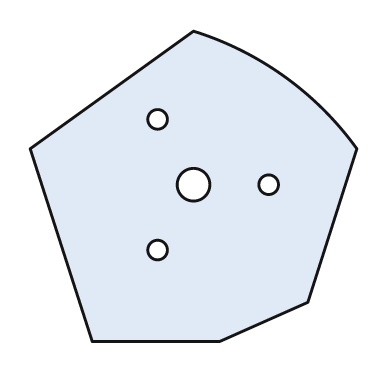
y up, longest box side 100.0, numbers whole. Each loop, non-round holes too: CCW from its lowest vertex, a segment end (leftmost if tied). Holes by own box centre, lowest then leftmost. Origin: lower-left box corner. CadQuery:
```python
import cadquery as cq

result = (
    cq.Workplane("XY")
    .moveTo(19.0, 0.0)
    .lineTo(58.0, 0.0)
    .lineTo(85.0, 12.0)
    .lineTo(100.0, 59.0)
    .threePointArc((78.0, 81.0), (50.0, 95.0))
    .lineTo(0.0, 59.0)
    .close()
    .moveTo(39.0, 28.0)
    .circle(3.0)
    .moveTo(50.0, 48.0)
    .circle(5.0)
    .moveTo(73.0, 48.0)
    .circle(3.0)
    .moveTo(39.0, 68.0)
    .circle(3.0)
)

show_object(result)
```